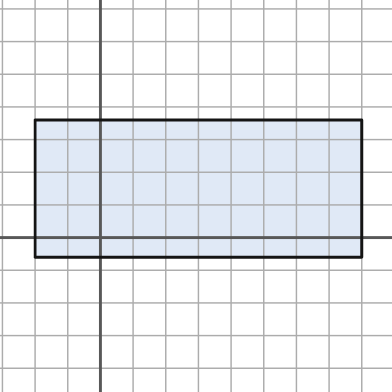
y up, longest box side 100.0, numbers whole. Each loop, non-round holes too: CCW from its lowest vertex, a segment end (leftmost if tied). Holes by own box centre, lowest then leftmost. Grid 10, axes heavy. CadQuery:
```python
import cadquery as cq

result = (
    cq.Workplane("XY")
    .moveTo(-20.0, -6.0)
    .lineTo(80.0, -6.0)
    .lineTo(80.0, 36.0)
    .lineTo(-20.0, 36.0)
    .close()
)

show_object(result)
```